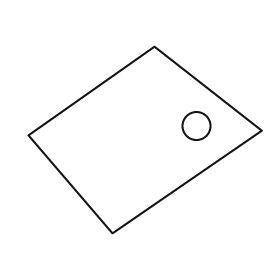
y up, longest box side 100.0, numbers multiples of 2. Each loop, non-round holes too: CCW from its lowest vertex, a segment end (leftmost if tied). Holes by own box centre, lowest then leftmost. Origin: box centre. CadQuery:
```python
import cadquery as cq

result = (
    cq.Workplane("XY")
    .moveTo(-14.0, -40.0)
    .lineTo(50.0, 4.0)
    .lineTo(4.0, 40.0)
    .lineTo(-50.0, 2.0)
    .close()
    .moveTo(22.0, 6.0)
    .circle(6.0)
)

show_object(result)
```